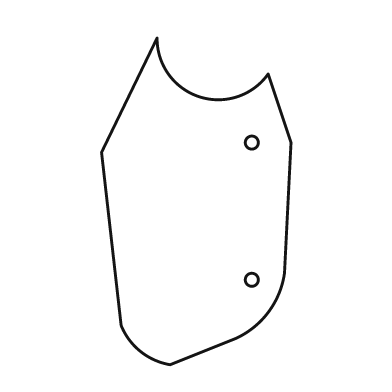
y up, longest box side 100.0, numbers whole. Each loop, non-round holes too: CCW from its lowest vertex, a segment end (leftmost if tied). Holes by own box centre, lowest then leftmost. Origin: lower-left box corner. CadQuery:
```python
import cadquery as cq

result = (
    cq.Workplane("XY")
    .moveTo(21.0, 0.0)
    .lineTo(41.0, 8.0)
    .threePointArc((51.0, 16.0), (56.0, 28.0))
    .lineTo(58.0, 68.0)
    .lineTo(51.0, 89.0)
    .threePointArc((30.0, 82.0), (17.0, 100.0))
    .lineTo(0.0, 65.0)
    .lineTo(6.0, 12.0)
    .threePointArc((12.0, 4.0), (21.0, 0.0))
    .close()
    .moveTo(46.0, 26.0)
    .circle(2.0)
    .moveTo(46.0, 68.0)
    .circle(2.0)
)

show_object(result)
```